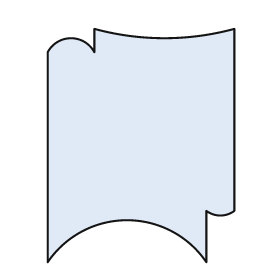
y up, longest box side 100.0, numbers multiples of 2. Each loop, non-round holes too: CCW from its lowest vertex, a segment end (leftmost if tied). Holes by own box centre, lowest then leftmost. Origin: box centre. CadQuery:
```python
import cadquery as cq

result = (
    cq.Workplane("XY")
    .moveTo(-40.0, -50.0)
    .threePointArc((-6.0, -32.0), (28.0, -50.0))
    .lineTo(28.0, -28.0)
    .threePointArc((34.0, -30.0), (40.0, -28.0))
    .lineTo(40.0, 50.0)
    .threePointArc((10.0, 46.0), (-20.0, 50.0))
    .lineTo(-20.0, 40.0)
    .threePointArc((-30.0, 46.0), (-40.0, 40.0))
    .close()
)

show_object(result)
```